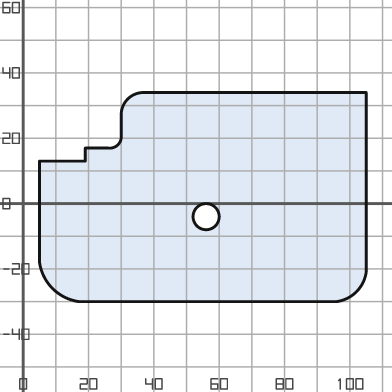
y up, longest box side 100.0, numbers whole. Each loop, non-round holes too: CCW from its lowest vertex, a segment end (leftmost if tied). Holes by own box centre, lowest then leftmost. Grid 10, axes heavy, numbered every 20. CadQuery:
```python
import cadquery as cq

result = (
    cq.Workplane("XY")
    .moveTo(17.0, -30.0)
    .lineTo(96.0, -30.0)
    .threePointArc((102.0, -27.0), (105.0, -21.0))
    .lineTo(105.0, 34.0)
    .lineTo(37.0, 34.0)
    .threePointArc((32.0, 32.0), (30.0, 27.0))
    .lineTo(30.0, 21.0)
    .threePointArc((29.0, 18.0), (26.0, 17.0))
    .lineTo(19.0, 17.0)
    .lineTo(19.0, 13.0)
    .lineTo(5.0, 13.0)
    .lineTo(5.0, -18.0)
    .threePointArc((9.0, -26.0), (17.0, -30.0))
    .close()
    .moveTo(56.0, -4.0)
    .circle(4.0)
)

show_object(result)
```